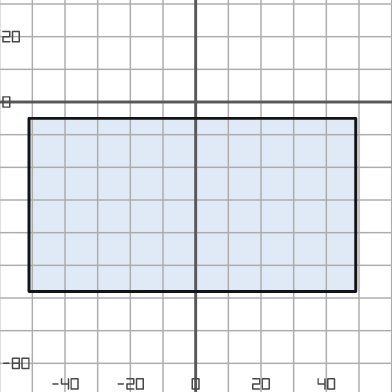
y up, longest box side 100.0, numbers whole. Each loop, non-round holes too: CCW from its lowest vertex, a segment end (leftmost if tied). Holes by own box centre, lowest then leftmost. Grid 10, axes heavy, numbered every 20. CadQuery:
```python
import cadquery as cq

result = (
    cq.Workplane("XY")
    .moveTo(-51.0, -58.0)
    .lineTo(49.0, -58.0)
    .lineTo(49.0, -5.0)
    .lineTo(-51.0, -5.0)
    .close()
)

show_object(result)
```